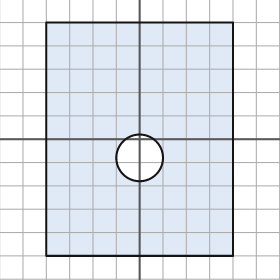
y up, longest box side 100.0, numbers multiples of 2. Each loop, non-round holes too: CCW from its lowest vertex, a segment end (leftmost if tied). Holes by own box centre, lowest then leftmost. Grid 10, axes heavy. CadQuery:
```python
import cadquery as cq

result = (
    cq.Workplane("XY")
    .moveTo(-40.0, -50.0)
    .lineTo(40.0, -50.0)
    .lineTo(40.0, 50.0)
    .lineTo(-40.0, 50.0)
    .close()
    .moveTo(0.0, -8.0)
    .circle(10.0)
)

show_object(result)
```